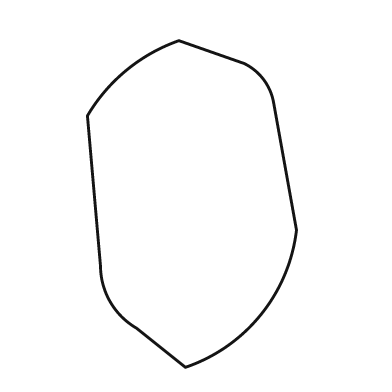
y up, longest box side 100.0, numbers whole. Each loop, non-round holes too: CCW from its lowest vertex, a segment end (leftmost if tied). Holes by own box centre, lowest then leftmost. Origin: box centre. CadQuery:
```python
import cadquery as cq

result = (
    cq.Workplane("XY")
    .moveTo(-2.0, -50.0)
    .threePointArc((21.0, -34.0), (32.0, -8.0))
    .lineTo(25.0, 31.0)
    .threePointArc((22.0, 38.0), (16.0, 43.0))
    .lineTo(-4.0, 50.0)
    .threePointArc((-20.0, 41.0), (-32.0, 27.0))
    .lineTo(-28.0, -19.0)
    .threePointArc((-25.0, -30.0), (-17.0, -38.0))
    .close()
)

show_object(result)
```